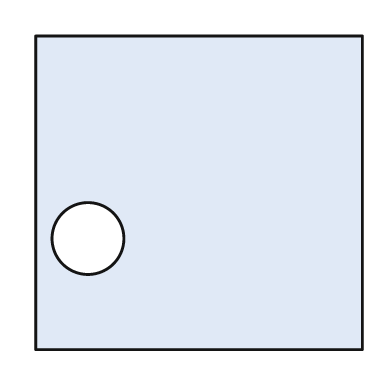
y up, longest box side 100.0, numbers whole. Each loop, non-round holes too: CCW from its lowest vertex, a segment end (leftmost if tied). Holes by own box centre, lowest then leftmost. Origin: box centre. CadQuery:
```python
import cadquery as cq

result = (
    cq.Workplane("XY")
    .moveTo(-50.0, -48.0)
    .lineTo(50.0, -48.0)
    .lineTo(50.0, 48.0)
    .lineTo(-50.0, 48.0)
    .close()
    .moveTo(-34.0, -14.0)
    .circle(11.0)
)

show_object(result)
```